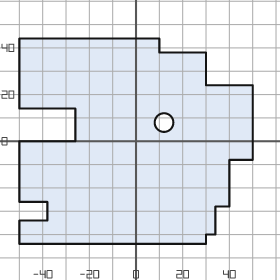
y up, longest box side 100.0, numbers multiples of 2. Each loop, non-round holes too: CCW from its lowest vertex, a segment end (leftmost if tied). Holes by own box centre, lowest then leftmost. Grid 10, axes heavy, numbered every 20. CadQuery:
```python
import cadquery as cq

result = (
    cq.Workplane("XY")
    .moveTo(-50.0, -44.0)
    .lineTo(30.0, -44.0)
    .lineTo(30.0, -40.0)
    .lineTo(34.0, -40.0)
    .lineTo(34.0, -28.0)
    .lineTo(40.0, -28.0)
    .lineTo(40.0, -8.0)
    .lineTo(50.0, -8.0)
    .lineTo(50.0, 24.0)
    .lineTo(30.0, 24.0)
    .lineTo(30.0, 38.0)
    .lineTo(10.0, 38.0)
    .lineTo(10.0, 44.0)
    .lineTo(-50.0, 44.0)
    .lineTo(-50.0, 14.0)
    .lineTo(-26.0, 14.0)
    .lineTo(-26.0, 0.0)
    .lineTo(-50.0, 0.0)
    .lineTo(-50.0, -26.0)
    .lineTo(-38.0, -26.0)
    .lineTo(-38.0, -34.0)
    .lineTo(-50.0, -34.0)
    .close()
    .moveTo(12.0, 8.0)
    .circle(4.0)
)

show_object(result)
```